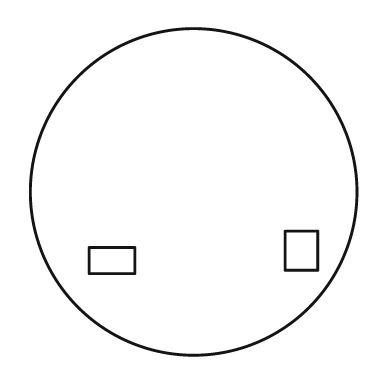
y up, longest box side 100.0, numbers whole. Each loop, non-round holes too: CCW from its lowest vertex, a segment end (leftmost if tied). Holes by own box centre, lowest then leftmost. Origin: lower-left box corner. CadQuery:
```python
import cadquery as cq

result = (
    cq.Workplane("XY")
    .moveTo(50.0, 50.0)
    .circle(50.0)
    .moveTo(18.0, 25.0)
    .lineTo(32.0, 25.0)
    .lineTo(32.0, 33.0)
    .lineTo(18.0, 33.0)
    .close()
    .moveTo(78.0, 26.0)
    .lineTo(88.0, 26.0)
    .lineTo(88.0, 38.0)
    .lineTo(78.0, 38.0)
    .close()
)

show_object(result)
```